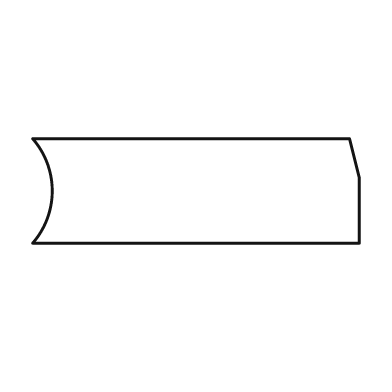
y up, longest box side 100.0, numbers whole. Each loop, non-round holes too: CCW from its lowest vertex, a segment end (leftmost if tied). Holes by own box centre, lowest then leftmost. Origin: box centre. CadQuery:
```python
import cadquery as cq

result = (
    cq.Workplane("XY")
    .moveTo(-50.0, -16.0)
    .lineTo(50.0, -16.0)
    .lineTo(50.0, 4.0)
    .lineTo(47.0, 16.0)
    .lineTo(-50.0, 16.0)
    .threePointArc((-44.0, 0.0), (-50.0, -16.0))
    .close()
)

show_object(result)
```